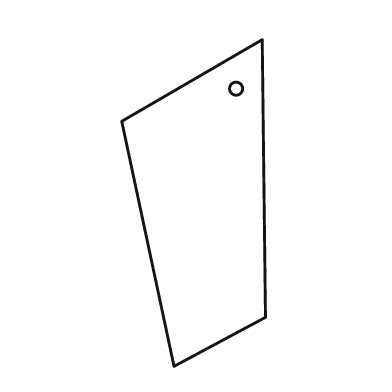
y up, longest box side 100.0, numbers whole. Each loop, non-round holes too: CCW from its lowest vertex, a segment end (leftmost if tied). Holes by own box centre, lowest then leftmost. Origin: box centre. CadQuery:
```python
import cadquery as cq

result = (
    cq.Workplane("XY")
    .moveTo(-6.0, -50.0)
    .lineTo(22.0, -35.0)
    .lineTo(21.0, 50.0)
    .lineTo(-22.0, 25.0)
    .close()
    .moveTo(13.0, 35.0)
    .circle(2.0)
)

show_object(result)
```